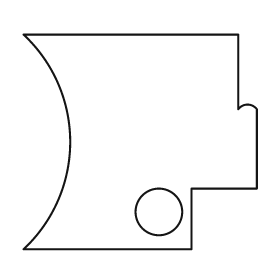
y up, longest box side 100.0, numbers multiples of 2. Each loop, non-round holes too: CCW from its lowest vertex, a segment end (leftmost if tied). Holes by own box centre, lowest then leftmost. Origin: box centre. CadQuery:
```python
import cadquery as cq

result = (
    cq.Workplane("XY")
    .moveTo(-50.0, -46.0)
    .lineTo(22.0, -46.0)
    .lineTo(22.0, -20.0)
    .lineTo(50.0, -20.0)
    .lineTo(50.0, 14.0)
    .threePointArc((46.0, 16.0), (42.0, 14.0))
    .lineTo(42.0, 46.0)
    .lineTo(-50.0, 46.0)
    .threePointArc((-30.0, 0.0), (-50.0, -46.0))
    .close()
    .moveTo(8.0, -30.0)
    .circle(10.0)
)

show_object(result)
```